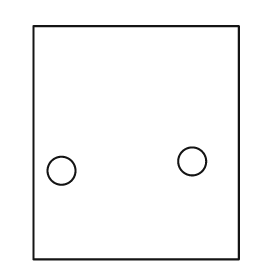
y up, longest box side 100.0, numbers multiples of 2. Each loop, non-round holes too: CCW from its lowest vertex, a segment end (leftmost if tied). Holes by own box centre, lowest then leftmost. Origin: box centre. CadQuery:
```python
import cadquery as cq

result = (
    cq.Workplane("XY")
    .moveTo(-44.0, -50.0)
    .lineTo(44.0, -50.0)
    .lineTo(44.0, 50.0)
    .lineTo(-44.0, 50.0)
    .close()
    .moveTo(-32.0, -12.0)
    .circle(6.0)
    .moveTo(24.0, -8.0)
    .circle(6.0)
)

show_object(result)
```